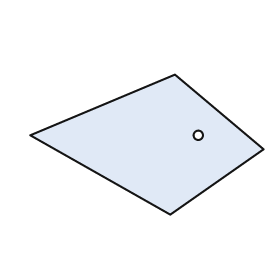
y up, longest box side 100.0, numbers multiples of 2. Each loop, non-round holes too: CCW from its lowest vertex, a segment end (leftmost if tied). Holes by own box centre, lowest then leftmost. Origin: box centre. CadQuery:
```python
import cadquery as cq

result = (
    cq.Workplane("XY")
    .moveTo(10.0, -30.0)
    .lineTo(50.0, -2.0)
    .lineTo(12.0, 30.0)
    .lineTo(-50.0, 4.0)
    .close()
    .moveTo(22.0, 4.0)
    .circle(2.0)
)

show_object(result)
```